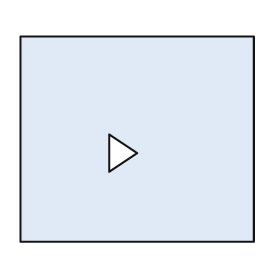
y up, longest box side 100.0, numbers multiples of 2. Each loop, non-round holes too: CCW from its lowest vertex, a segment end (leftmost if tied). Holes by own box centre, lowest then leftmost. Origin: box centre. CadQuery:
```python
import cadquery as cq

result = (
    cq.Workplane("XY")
    .moveTo(-50.0, -44.0)
    .lineTo(50.0, -44.0)
    .lineTo(50.0, 44.0)
    .lineTo(-50.0, 44.0)
    .close()
    .moveTo(-12.0, -14.0)
    .lineTo(0.0, -6.0)
    .lineTo(-12.0, 2.0)
    .close()
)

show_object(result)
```